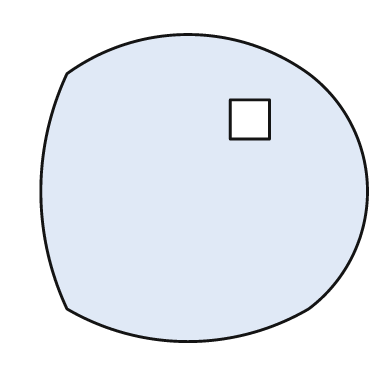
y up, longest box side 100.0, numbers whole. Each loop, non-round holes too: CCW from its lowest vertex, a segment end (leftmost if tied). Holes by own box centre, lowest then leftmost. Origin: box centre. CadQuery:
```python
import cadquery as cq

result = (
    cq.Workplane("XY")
    .moveTo(-42.0, -37.0)
    .threePointArc((-5.0, -47.0), (32.0, -37.0))
    .threePointArc((50.0, -1.0), (32.0, 35.0))
    .threePointArc((-5.0, 47.0), (-42.0, 35.0))
    .threePointArc((-50.0, -1.0), (-42.0, -37.0))
    .close()
    .moveTo(8.0, 15.0)
    .lineTo(20.0, 15.0)
    .lineTo(20.0, 27.0)
    .lineTo(8.0, 27.0)
    .close()
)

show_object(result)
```